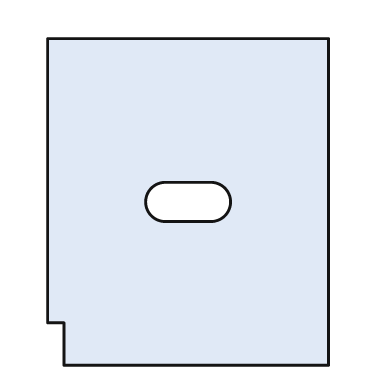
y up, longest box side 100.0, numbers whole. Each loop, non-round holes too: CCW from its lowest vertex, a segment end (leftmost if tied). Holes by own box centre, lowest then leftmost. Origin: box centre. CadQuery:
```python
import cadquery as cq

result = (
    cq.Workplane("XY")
    .moveTo(-38.0, -50.0)
    .lineTo(43.0, -50.0)
    .lineTo(43.0, 50.0)
    .lineTo(-43.0, 50.0)
    .lineTo(-43.0, -37.0)
    .lineTo(-38.0, -37.0)
    .close()
    .moveTo(-7.0, -6.0)
    .lineTo(7.0, -6.0)
    .threePointArc((13.0, 0.0), (7.0, 6.0))
    .lineTo(-7.0, 6.0)
    .threePointArc((-13.0, 0.0), (-7.0, -6.0))
    .close()
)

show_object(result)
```